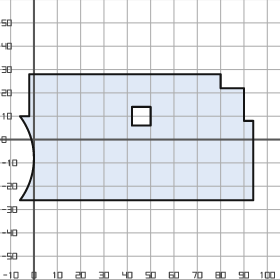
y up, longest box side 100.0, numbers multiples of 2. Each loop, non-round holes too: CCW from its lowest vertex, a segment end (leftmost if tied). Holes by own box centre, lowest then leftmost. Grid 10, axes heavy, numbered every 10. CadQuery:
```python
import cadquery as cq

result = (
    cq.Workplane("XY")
    .moveTo(-6.0, -26.0)
    .lineTo(94.0, -26.0)
    .lineTo(94.0, 8.0)
    .lineTo(90.0, 8.0)
    .lineTo(90.0, 22.0)
    .lineTo(80.0, 22.0)
    .lineTo(80.0, 28.0)
    .lineTo(-2.0, 28.0)
    .lineTo(-2.0, 10.0)
    .lineTo(-6.0, 10.0)
    .threePointArc((0.0, -8.0), (-6.0, -26.0))
    .close()
    .moveTo(42.0, 6.0)
    .lineTo(50.0, 6.0)
    .lineTo(50.0, 14.0)
    .lineTo(42.0, 14.0)
    .close()
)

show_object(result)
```